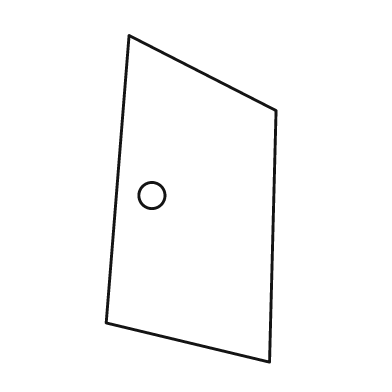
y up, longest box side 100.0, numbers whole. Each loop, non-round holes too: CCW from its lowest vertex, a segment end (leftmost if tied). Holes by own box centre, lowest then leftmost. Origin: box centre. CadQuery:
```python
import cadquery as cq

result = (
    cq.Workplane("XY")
    .moveTo(24.0, -50.0)
    .lineTo(26.0, 27.0)
    .lineTo(-19.0, 50.0)
    .lineTo(-26.0, -38.0)
    .close()
    .moveTo(-12.0, 1.0)
    .circle(4.0)
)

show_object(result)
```